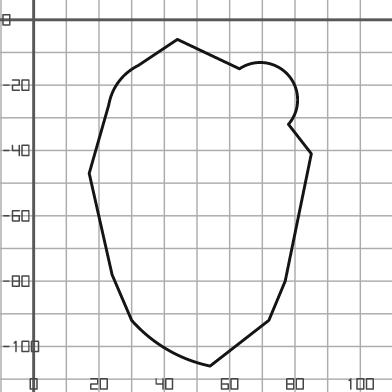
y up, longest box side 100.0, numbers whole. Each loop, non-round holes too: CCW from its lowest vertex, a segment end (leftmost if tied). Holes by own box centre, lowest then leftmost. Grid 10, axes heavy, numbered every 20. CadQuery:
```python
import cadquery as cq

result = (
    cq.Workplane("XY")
    .moveTo(54.0, -106.0)
    .lineTo(72.0, -92.0)
    .lineTo(77.0, -80.0)
    .lineTo(85.0, -41.0)
    .lineTo(78.0, -32.0)
    .threePointArc((78.0, -17.0), (63.0, -15.0))
    .lineTo(44.0, -6.0)
    .lineTo(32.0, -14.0)
    .threePointArc((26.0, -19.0), (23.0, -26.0))
    .lineTo(17.0, -47.0)
    .lineTo(24.0, -78.0)
    .lineTo(30.0, -92.0)
    .threePointArc((41.0, -101.0), (54.0, -106.0))
    .close()
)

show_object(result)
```